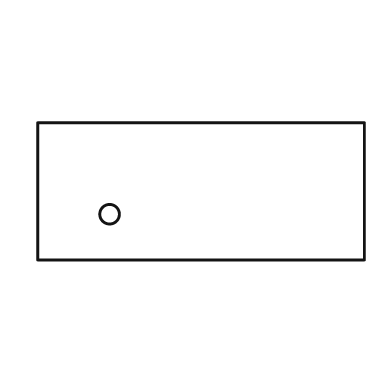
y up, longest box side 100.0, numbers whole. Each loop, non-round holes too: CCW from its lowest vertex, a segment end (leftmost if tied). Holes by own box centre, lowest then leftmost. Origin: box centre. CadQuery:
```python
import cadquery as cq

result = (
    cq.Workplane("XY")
    .moveTo(-50.0, -21.0)
    .lineTo(50.0, -21.0)
    .lineTo(50.0, 21.0)
    .lineTo(-50.0, 21.0)
    .close()
    .moveTo(-28.0, -7.0)
    .circle(3.0)
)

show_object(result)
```